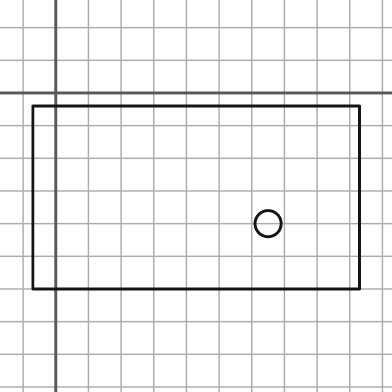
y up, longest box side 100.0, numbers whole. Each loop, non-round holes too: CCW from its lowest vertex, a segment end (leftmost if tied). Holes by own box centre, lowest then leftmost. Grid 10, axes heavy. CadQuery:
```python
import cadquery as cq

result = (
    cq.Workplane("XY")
    .moveTo(-7.0, -60.0)
    .lineTo(93.0, -60.0)
    .lineTo(93.0, -4.0)
    .lineTo(-7.0, -4.0)
    .close()
    .moveTo(65.0, -40.0)
    .circle(4.0)
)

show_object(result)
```